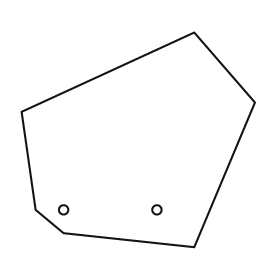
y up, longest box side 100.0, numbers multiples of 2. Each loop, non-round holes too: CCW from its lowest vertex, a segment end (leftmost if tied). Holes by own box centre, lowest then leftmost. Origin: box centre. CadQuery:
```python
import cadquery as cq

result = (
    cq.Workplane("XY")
    .moveTo(24.0, -46.0)
    .lineTo(50.0, 16.0)
    .lineTo(24.0, 46.0)
    .lineTo(-50.0, 12.0)
    .lineTo(-44.0, -30.0)
    .lineTo(-32.0, -40.0)
    .close()
    .moveTo(-32.0, -30.0)
    .circle(2.0)
    .moveTo(8.0, -30.0)
    .circle(2.0)
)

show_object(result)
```